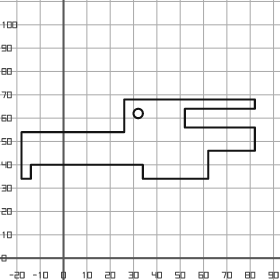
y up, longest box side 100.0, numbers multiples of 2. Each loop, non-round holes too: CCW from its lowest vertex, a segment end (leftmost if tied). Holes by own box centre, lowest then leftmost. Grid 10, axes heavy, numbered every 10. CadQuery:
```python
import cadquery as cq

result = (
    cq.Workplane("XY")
    .moveTo(-18.0, 34.0)
    .lineTo(-14.0, 34.0)
    .lineTo(-14.0, 40.0)
    .lineTo(34.0, 40.0)
    .lineTo(34.0, 34.0)
    .lineTo(62.0, 34.0)
    .lineTo(62.0, 46.0)
    .lineTo(82.0, 46.0)
    .lineTo(82.0, 56.0)
    .lineTo(52.0, 56.0)
    .lineTo(52.0, 64.0)
    .lineTo(82.0, 64.0)
    .lineTo(82.0, 68.0)
    .lineTo(26.0, 68.0)
    .lineTo(26.0, 54.0)
    .lineTo(-18.0, 54.0)
    .close()
    .moveTo(32.0, 62.0)
    .circle(2.0)
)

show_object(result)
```